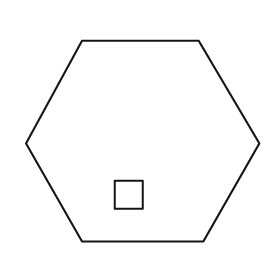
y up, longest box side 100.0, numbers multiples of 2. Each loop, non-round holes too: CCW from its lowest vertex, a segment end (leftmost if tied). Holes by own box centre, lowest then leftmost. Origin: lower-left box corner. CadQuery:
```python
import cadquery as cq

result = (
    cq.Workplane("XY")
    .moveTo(24.0, 0.0)
    .lineTo(76.0, 0.0)
    .lineTo(100.0, 42.0)
    .lineTo(74.0, 86.0)
    .lineTo(24.0, 86.0)
    .lineTo(0.0, 42.0)
    .close()
    .moveTo(38.0, 14.0)
    .lineTo(50.0, 14.0)
    .lineTo(50.0, 26.0)
    .lineTo(38.0, 26.0)
    .close()
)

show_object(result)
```